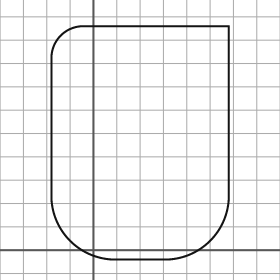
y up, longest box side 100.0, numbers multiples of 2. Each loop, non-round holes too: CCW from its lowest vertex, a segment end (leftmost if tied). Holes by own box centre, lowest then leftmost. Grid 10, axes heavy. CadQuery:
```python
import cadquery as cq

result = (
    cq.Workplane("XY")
    .moveTo(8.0, -4.0)
    .lineTo(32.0, -4.0)
    .threePointArc((50.0, 4.0), (58.0, 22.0))
    .lineTo(58.0, 96.0)
    .lineTo(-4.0, 96.0)
    .threePointArc((-14.0, 92.0), (-18.0, 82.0))
    .lineTo(-18.0, 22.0)
    .threePointArc((-10.0, 4.0), (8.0, -4.0))
    .close()
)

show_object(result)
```